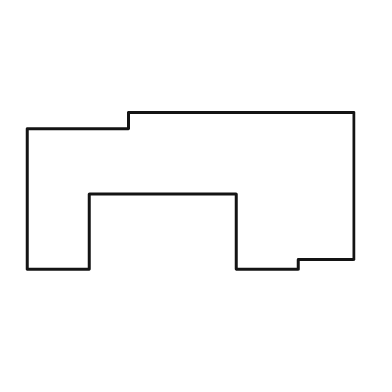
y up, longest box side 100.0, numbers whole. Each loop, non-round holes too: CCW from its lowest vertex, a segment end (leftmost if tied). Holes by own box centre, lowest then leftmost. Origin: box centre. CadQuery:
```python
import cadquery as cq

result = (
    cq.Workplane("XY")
    .moveTo(-50.0, -24.0)
    .lineTo(-31.0, -24.0)
    .lineTo(-31.0, -1.0)
    .lineTo(14.0, -1.0)
    .lineTo(14.0, -24.0)
    .lineTo(33.0, -24.0)
    .lineTo(33.0, -21.0)
    .lineTo(50.0, -21.0)
    .lineTo(50.0, 24.0)
    .lineTo(-19.0, 24.0)
    .lineTo(-19.0, 19.0)
    .lineTo(-50.0, 19.0)
    .close()
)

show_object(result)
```